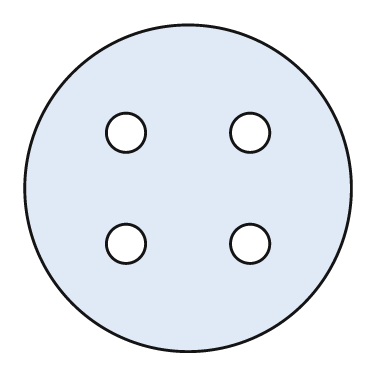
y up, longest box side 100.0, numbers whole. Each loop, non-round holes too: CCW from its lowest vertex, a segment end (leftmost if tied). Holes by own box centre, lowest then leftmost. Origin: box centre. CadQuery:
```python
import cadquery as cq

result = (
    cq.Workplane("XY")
    .moveTo(0.0, 0.0)
    .circle(50.0)
    .moveTo(-19.0, -17.0)
    .circle(6.0)
    .moveTo(19.0, -17.0)
    .circle(6.0)
    .moveTo(-19.0, 17.0)
    .circle(6.0)
    .moveTo(19.0, 17.0)
    .circle(6.0)
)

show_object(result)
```